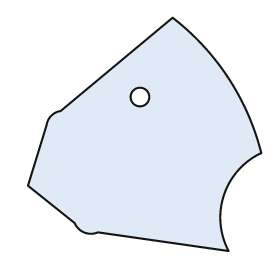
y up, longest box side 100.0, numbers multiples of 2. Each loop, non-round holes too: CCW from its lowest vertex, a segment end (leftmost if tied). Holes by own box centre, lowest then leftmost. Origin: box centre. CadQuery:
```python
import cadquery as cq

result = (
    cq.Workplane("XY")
    .moveTo(36.0, -50.0)
    .threePointArc((34.0, -26.0), (50.0, -8.0))
    .threePointArc((36.0, 24.0), (12.0, 50.0))
    .lineTo(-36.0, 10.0)
    .threePointArc((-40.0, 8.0), (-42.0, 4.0))
    .lineTo(-50.0, -22.0)
    .lineTo(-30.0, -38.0)
    .threePointArc((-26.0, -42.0), (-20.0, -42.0))
    .close()
    .moveTo(-2.0, 16.0)
    .circle(4.0)
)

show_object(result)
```